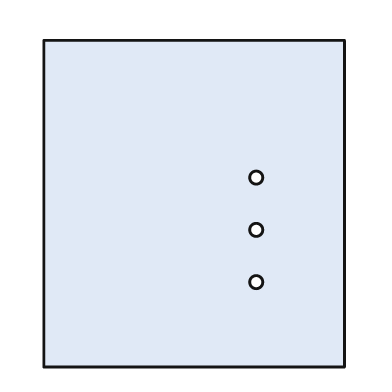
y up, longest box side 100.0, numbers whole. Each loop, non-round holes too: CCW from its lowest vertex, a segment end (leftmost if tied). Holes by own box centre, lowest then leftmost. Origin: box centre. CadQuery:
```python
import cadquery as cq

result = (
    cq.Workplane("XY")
    .moveTo(-46.0, -50.0)
    .lineTo(46.0, -50.0)
    .lineTo(46.0, 50.0)
    .lineTo(-46.0, 50.0)
    .close()
    .moveTo(19.0, -24.0)
    .circle(2.0)
    .moveTo(19.0, -8.0)
    .circle(2.0)
    .moveTo(19.0, 8.0)
    .circle(2.0)
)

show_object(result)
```